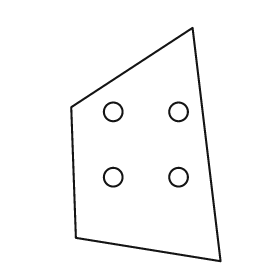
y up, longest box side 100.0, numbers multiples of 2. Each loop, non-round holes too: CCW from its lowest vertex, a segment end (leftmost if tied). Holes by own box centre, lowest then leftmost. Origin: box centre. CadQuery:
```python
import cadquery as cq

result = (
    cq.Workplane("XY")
    .moveTo(32.0, -50.0)
    .lineTo(20.0, 50.0)
    .lineTo(-32.0, 16.0)
    .lineTo(-30.0, -40.0)
    .close()
    .moveTo(-14.0, -14.0)
    .circle(4.0)
    .moveTo(14.0, -14.0)
    .circle(4.0)
    .moveTo(-14.0, 14.0)
    .circle(4.0)
    .moveTo(14.0, 14.0)
    .circle(4.0)
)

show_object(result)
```